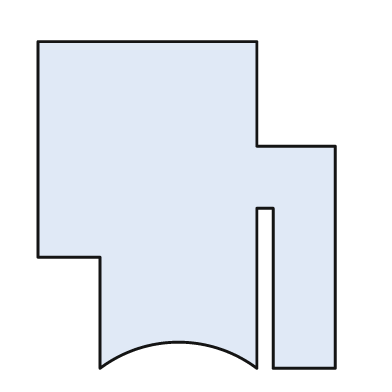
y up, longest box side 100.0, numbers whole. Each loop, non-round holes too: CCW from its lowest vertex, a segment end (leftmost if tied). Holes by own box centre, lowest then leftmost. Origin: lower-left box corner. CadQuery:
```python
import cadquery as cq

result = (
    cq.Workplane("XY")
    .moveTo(19.0, 0.0)
    .threePointArc((43.0, 8.0), (67.0, 0.0))
    .lineTo(67.0, 49.0)
    .lineTo(72.0, 49.0)
    .lineTo(72.0, 0.0)
    .lineTo(91.0, 0.0)
    .lineTo(91.0, 68.0)
    .lineTo(67.0, 68.0)
    .lineTo(67.0, 100.0)
    .lineTo(0.0, 100.0)
    .lineTo(0.0, 34.0)
    .lineTo(19.0, 34.0)
    .close()
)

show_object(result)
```